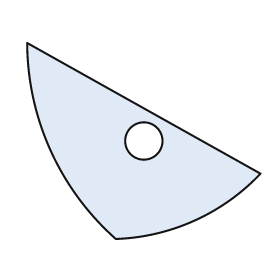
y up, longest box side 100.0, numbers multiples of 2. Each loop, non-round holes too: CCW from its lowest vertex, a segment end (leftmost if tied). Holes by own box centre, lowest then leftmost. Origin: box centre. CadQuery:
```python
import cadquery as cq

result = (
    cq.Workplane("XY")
    .moveTo(-12.0, -42.0)
    .threePointArc((22.0, -34.0), (50.0, -14.0))
    .lineTo(-50.0, 42.0)
    .threePointArc((-40.0, -4.0), (-12.0, -42.0))
    .close()
    .moveTo(0.0, 0.0)
    .circle(8.0)
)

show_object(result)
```